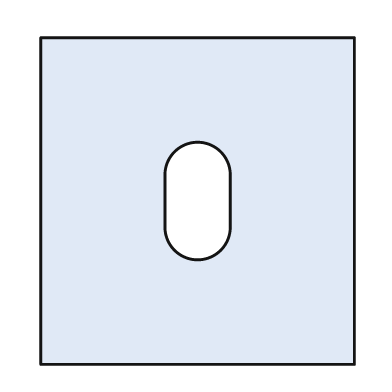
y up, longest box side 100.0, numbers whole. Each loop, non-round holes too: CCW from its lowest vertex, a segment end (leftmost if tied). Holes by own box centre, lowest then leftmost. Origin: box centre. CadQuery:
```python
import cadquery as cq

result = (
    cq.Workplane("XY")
    .moveTo(-48.0, -50.0)
    .lineTo(48.0, -50.0)
    .lineTo(48.0, 50.0)
    .lineTo(-48.0, 50.0)
    .close()
    .moveTo(-10.0, -8.0)
    .threePointArc((0.0, -18.0), (10.0, -8.0))
    .lineTo(10.0, 8.0)
    .threePointArc((0.0, 18.0), (-10.0, 8.0))
    .close()
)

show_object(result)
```